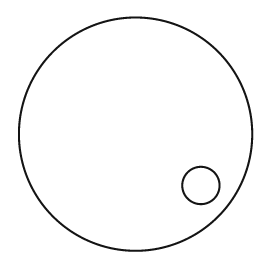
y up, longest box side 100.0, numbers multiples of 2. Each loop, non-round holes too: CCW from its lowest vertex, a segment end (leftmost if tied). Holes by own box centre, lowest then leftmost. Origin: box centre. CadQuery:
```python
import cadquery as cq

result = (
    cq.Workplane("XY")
    .moveTo(0.0, 0.0)
    .circle(50.0)
    .moveTo(28.0, -22.0)
    .circle(8.0)
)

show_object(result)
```